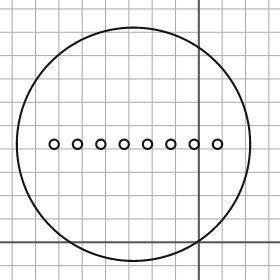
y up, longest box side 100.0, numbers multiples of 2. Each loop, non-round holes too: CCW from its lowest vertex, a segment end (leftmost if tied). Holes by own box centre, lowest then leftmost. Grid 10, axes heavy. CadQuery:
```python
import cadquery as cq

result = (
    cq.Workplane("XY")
    .moveTo(-28.0, 42.0)
    .circle(50.0)
    .moveTo(-62.0, 42.0)
    .circle(2.0)
    .moveTo(-52.0, 42.0)
    .circle(2.0)
    .moveTo(-42.0, 42.0)
    .circle(2.0)
    .moveTo(-32.0, 42.0)
    .circle(2.0)
    .moveTo(-22.0, 42.0)
    .circle(2.0)
    .moveTo(-12.0, 42.0)
    .circle(2.0)
    .moveTo(-2.0, 42.0)
    .circle(2.0)
    .moveTo(8.0, 42.0)
    .circle(2.0)
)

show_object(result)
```